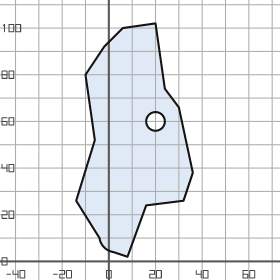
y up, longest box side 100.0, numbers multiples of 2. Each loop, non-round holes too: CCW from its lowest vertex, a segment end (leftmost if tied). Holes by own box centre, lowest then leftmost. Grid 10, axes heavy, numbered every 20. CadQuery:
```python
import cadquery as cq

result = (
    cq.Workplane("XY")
    .moveTo(8.0, 2.0)
    .lineTo(16.0, 24.0)
    .lineTo(32.0, 26.0)
    .lineTo(36.0, 38.0)
    .lineTo(30.0, 66.0)
    .lineTo(24.0, 74.0)
    .lineTo(20.0, 102.0)
    .lineTo(6.0, 100.0)
    .lineTo(-2.0, 92.0)
    .lineTo(-10.0, 80.0)
    .lineTo(-6.0, 52.0)
    .lineTo(-14.0, 26.0)
    .lineTo(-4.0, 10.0)
    .threePointArc((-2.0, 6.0), (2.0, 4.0))
    .close()
    .moveTo(20.0, 60.0)
    .circle(4.0)
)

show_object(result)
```